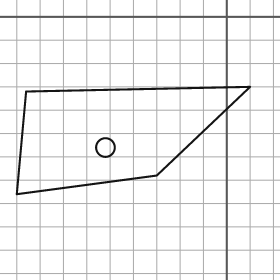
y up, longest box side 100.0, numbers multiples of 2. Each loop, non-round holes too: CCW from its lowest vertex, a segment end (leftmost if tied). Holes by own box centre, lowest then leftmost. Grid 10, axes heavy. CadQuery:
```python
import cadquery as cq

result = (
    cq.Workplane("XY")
    .moveTo(-90.0, -76.0)
    .lineTo(-30.0, -68.0)
    .lineTo(10.0, -30.0)
    .lineTo(-86.0, -32.0)
    .close()
    .moveTo(-52.0, -56.0)
    .circle(4.0)
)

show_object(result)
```